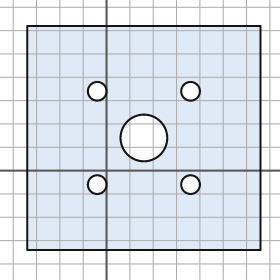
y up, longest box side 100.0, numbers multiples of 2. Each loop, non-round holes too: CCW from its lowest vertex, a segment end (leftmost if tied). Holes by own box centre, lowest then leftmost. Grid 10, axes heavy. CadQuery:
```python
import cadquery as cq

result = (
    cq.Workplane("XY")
    .moveTo(-34.0, -34.0)
    .lineTo(66.0, -34.0)
    .lineTo(66.0, 62.0)
    .lineTo(-34.0, 62.0)
    .close()
    .moveTo(-4.0, -6.0)
    .circle(4.0)
    .moveTo(36.0, -6.0)
    .circle(4.0)
    .moveTo(16.0, 14.0)
    .circle(10.0)
    .moveTo(-4.0, 34.0)
    .circle(4.0)
    .moveTo(36.0, 34.0)
    .circle(4.0)
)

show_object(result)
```